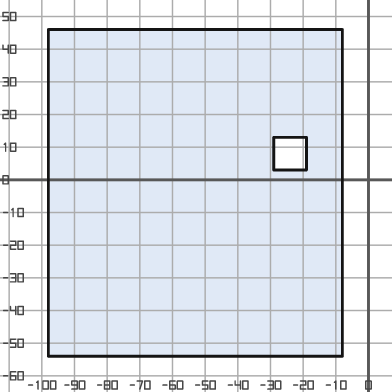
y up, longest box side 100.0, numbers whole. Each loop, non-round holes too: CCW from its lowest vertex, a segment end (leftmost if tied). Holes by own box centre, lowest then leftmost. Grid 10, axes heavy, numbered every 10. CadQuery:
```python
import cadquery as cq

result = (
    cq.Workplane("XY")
    .moveTo(-98.0, -54.0)
    .lineTo(-8.0, -54.0)
    .lineTo(-8.0, 46.0)
    .lineTo(-98.0, 46.0)
    .close()
    .moveTo(-29.0, 3.0)
    .lineTo(-19.0, 3.0)
    .lineTo(-19.0, 13.0)
    .lineTo(-29.0, 13.0)
    .close()
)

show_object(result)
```